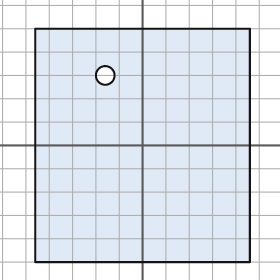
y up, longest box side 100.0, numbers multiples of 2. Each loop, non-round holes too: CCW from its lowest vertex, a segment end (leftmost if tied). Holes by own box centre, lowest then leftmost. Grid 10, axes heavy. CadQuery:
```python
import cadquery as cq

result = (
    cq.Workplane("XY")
    .moveTo(-46.0, -50.0)
    .lineTo(46.0, -50.0)
    .lineTo(46.0, 50.0)
    .lineTo(-46.0, 50.0)
    .close()
    .moveTo(-16.0, 30.0)
    .circle(4.0)
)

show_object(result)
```